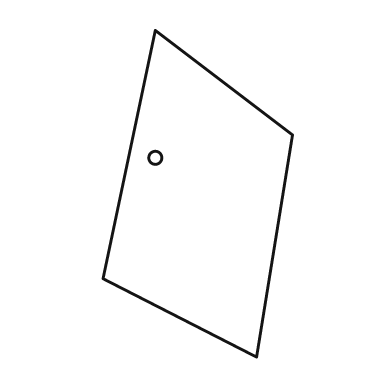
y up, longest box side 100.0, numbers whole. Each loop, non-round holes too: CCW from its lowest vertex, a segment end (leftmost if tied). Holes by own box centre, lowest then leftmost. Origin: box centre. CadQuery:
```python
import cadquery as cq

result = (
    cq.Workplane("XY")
    .moveTo(18.0, -50.0)
    .lineTo(29.0, 18.0)
    .lineTo(-13.0, 50.0)
    .lineTo(-29.0, -26.0)
    .close()
    .moveTo(-13.0, 11.0)
    .circle(2.0)
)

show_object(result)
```